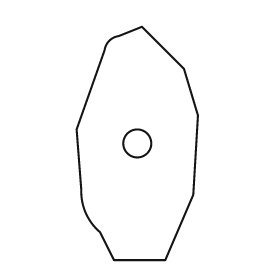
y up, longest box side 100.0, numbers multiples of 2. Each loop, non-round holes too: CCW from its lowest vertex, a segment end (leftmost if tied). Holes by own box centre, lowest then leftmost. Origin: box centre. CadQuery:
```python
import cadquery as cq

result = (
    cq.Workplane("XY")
    .moveTo(-10.0, -50.0)
    .lineTo(12.0, -50.0)
    .lineTo(24.0, -22.0)
    .lineTo(26.0, 12.0)
    .lineTo(20.0, 32.0)
    .lineTo(2.0, 50.0)
    .lineTo(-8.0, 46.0)
    .threePointArc((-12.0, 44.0), (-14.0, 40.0))
    .lineTo(-26.0, 6.0)
    .lineTo(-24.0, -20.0)
    .threePointArc((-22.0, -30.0), (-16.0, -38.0))
    .close()
    .moveTo(0.0, 0.0)
    .circle(6.0)
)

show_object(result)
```